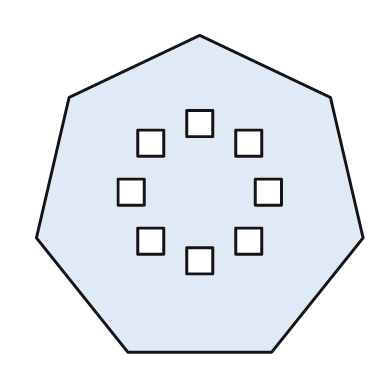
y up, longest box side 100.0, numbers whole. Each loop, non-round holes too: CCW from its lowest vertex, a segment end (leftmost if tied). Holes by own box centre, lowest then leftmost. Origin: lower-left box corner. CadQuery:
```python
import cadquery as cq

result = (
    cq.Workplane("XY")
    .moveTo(28.0, 0.0)
    .lineTo(72.0, 0.0)
    .lineTo(100.0, 35.0)
    .lineTo(90.0, 78.0)
    .lineTo(50.0, 97.0)
    .lineTo(10.0, 78.0)
    .lineTo(0.0, 35.0)
    .close()
    .moveTo(46.0, 24.0)
    .lineTo(54.0, 24.0)
    .lineTo(54.0, 32.0)
    .lineTo(46.0, 32.0)
    .close()
    .moveTo(31.0, 30.0)
    .lineTo(39.0, 30.0)
    .lineTo(39.0, 38.0)
    .lineTo(31.0, 38.0)
    .close()
    .moveTo(61.0, 30.0)
    .lineTo(69.0, 30.0)
    .lineTo(69.0, 38.0)
    .lineTo(61.0, 38.0)
    .close()
    .moveTo(25.0, 45.0)
    .lineTo(33.0, 45.0)
    .lineTo(33.0, 53.0)
    .lineTo(25.0, 53.0)
    .close()
    .moveTo(67.0, 45.0)
    .lineTo(75.0, 45.0)
    .lineTo(75.0, 53.0)
    .lineTo(67.0, 53.0)
    .close()
    .moveTo(31.0, 60.0)
    .lineTo(39.0, 60.0)
    .lineTo(39.0, 68.0)
    .lineTo(31.0, 68.0)
    .close()
    .moveTo(61.0, 60.0)
    .lineTo(69.0, 60.0)
    .lineTo(69.0, 68.0)
    .lineTo(61.0, 68.0)
    .close()
    .moveTo(46.0, 66.0)
    .lineTo(54.0, 66.0)
    .lineTo(54.0, 74.0)
    .lineTo(46.0, 74.0)
    .close()
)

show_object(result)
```